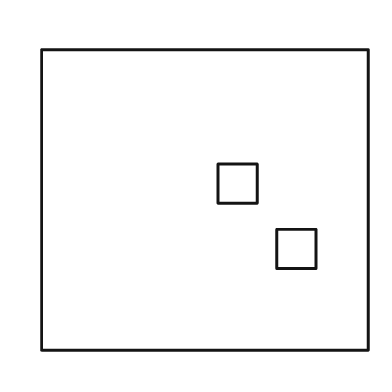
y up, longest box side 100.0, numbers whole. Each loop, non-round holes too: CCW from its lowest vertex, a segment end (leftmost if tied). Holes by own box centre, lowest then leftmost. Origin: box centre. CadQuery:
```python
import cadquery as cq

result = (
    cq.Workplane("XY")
    .moveTo(-50.0, -46.0)
    .lineTo(50.0, -46.0)
    .lineTo(50.0, 46.0)
    .lineTo(-50.0, 46.0)
    .close()
    .moveTo(22.0, -21.0)
    .lineTo(34.0, -21.0)
    .lineTo(34.0, -9.0)
    .lineTo(22.0, -9.0)
    .close()
    .moveTo(4.0, -1.0)
    .lineTo(16.0, -1.0)
    .lineTo(16.0, 11.0)
    .lineTo(4.0, 11.0)
    .close()
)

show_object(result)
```